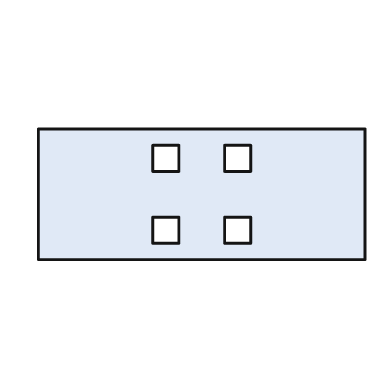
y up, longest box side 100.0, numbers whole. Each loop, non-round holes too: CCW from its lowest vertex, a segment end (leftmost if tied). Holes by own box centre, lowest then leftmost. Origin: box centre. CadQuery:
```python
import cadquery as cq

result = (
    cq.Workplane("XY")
    .moveTo(-50.0, -20.0)
    .lineTo(50.0, -20.0)
    .lineTo(50.0, 20.0)
    .lineTo(-50.0, 20.0)
    .close()
    .moveTo(-15.0, -15.0)
    .lineTo(-7.0, -15.0)
    .lineTo(-7.0, -7.0)
    .lineTo(-15.0, -7.0)
    .close()
    .moveTo(7.0, -15.0)
    .lineTo(15.0, -15.0)
    .lineTo(15.0, -7.0)
    .lineTo(7.0, -7.0)
    .close()
    .moveTo(-15.0, 7.0)
    .lineTo(-7.0, 7.0)
    .lineTo(-7.0, 15.0)
    .lineTo(-15.0, 15.0)
    .close()
    .moveTo(7.0, 7.0)
    .lineTo(15.0, 7.0)
    .lineTo(15.0, 15.0)
    .lineTo(7.0, 15.0)
    .close()
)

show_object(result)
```